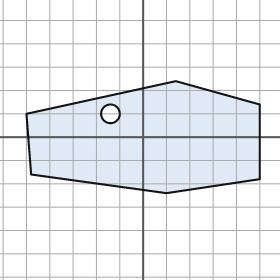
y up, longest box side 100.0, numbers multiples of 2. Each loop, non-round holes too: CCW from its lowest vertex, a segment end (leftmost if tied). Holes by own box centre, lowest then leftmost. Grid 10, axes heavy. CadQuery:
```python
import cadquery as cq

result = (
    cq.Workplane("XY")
    .moveTo(10.0, -24.0)
    .lineTo(50.0, -18.0)
    .lineTo(50.0, 14.0)
    .lineTo(14.0, 24.0)
    .lineTo(-50.0, 10.0)
    .lineTo(-48.0, -16.0)
    .close()
    .moveTo(-14.0, 10.0)
    .circle(4.0)
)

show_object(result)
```